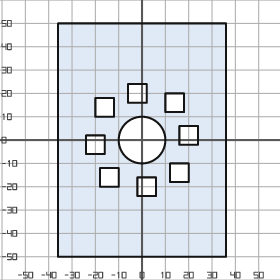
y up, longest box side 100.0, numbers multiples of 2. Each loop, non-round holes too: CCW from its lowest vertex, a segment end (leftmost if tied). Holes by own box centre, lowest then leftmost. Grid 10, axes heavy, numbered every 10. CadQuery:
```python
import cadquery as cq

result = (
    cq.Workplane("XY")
    .moveTo(-36.0, -50.0)
    .lineTo(36.0, -50.0)
    .lineTo(36.0, 50.0)
    .lineTo(-36.0, 50.0)
    .close()
    .moveTo(-2.0, -24.0)
    .lineTo(6.0, -24.0)
    .lineTo(6.0, -16.0)
    .lineTo(-2.0, -16.0)
    .close()
    .moveTo(-18.0, -20.0)
    .lineTo(-10.0, -20.0)
    .lineTo(-10.0, -12.0)
    .lineTo(-18.0, -12.0)
    .close()
    .moveTo(12.0, -18.0)
    .lineTo(20.0, -18.0)
    .lineTo(20.0, -10.0)
    .lineTo(12.0, -10.0)
    .close()
    .moveTo(-24.0, -6.0)
    .lineTo(-16.0, -6.0)
    .lineTo(-16.0, 2.0)
    .lineTo(-24.0, 2.0)
    .close()
    .moveTo(0.0, 0.0)
    .circle(10.0)
    .moveTo(16.0, -2.0)
    .lineTo(24.0, -2.0)
    .lineTo(24.0, 6.0)
    .lineTo(16.0, 6.0)
    .close()
    .moveTo(-20.0, 10.0)
    .lineTo(-12.0, 10.0)
    .lineTo(-12.0, 18.0)
    .lineTo(-20.0, 18.0)
    .close()
    .moveTo(10.0, 12.0)
    .lineTo(18.0, 12.0)
    .lineTo(18.0, 20.0)
    .lineTo(10.0, 20.0)
    .close()
    .moveTo(-6.0, 16.0)
    .lineTo(2.0, 16.0)
    .lineTo(2.0, 24.0)
    .lineTo(-6.0, 24.0)
    .close()
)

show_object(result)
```